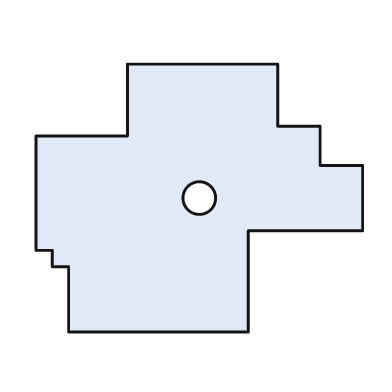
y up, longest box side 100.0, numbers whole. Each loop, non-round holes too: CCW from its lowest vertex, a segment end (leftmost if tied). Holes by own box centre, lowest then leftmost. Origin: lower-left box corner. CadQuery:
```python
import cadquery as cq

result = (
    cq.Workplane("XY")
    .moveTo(10.0, 0.0)
    .lineTo(65.0, 0.0)
    .lineTo(65.0, 31.0)
    .lineTo(100.0, 31.0)
    .lineTo(100.0, 51.0)
    .lineTo(87.0, 51.0)
    .lineTo(87.0, 63.0)
    .lineTo(74.0, 63.0)
    .lineTo(74.0, 82.0)
    .lineTo(28.0, 82.0)
    .lineTo(28.0, 60.0)
    .lineTo(0.0, 60.0)
    .lineTo(0.0, 25.0)
    .lineTo(5.0, 25.0)
    .lineTo(5.0, 20.0)
    .lineTo(10.0, 20.0)
    .close()
    .moveTo(50.0, 41.0)
    .circle(5.0)
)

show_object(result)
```